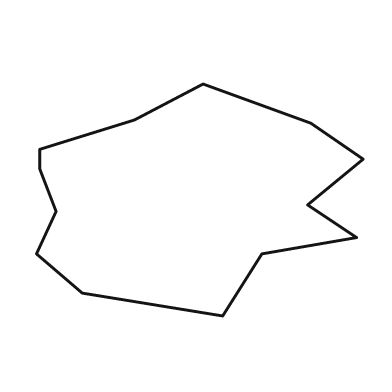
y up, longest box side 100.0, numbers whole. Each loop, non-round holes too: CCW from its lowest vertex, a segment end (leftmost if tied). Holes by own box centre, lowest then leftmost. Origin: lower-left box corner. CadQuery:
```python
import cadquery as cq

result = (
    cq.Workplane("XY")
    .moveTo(57.0, 0.0)
    .lineTo(69.0, 19.0)
    .lineTo(98.0, 24.0)
    .lineTo(83.0, 34.0)
    .lineTo(100.0, 48.0)
    .lineTo(84.0, 59.0)
    .lineTo(51.0, 71.0)
    .lineTo(30.0, 60.0)
    .lineTo(1.0, 51.0)
    .lineTo(1.0, 45.0)
    .lineTo(6.0, 32.0)
    .lineTo(0.0, 19.0)
    .lineTo(14.0, 7.0)
    .close()
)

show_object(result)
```